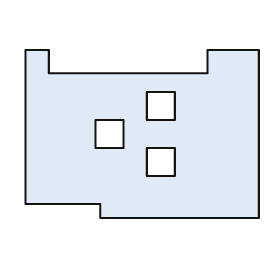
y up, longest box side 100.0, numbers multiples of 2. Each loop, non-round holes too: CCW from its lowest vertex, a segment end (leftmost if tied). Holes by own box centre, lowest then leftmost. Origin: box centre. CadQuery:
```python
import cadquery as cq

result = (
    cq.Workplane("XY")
    .moveTo(-18.0, -36.0)
    .lineTo(50.0, -36.0)
    .lineTo(50.0, 36.0)
    .lineTo(28.0, 36.0)
    .lineTo(28.0, 26.0)
    .lineTo(-40.0, 26.0)
    .lineTo(-40.0, 36.0)
    .lineTo(-50.0, 36.0)
    .lineTo(-50.0, -30.0)
    .lineTo(-18.0, -30.0)
    .close()
    .moveTo(2.0, -18.0)
    .lineTo(14.0, -18.0)
    .lineTo(14.0, -6.0)
    .lineTo(2.0, -6.0)
    .close()
    .moveTo(-20.0, -6.0)
    .lineTo(-8.0, -6.0)
    .lineTo(-8.0, 6.0)
    .lineTo(-20.0, 6.0)
    .close()
    .moveTo(2.0, 6.0)
    .lineTo(14.0, 6.0)
    .lineTo(14.0, 18.0)
    .lineTo(2.0, 18.0)
    .close()
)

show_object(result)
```